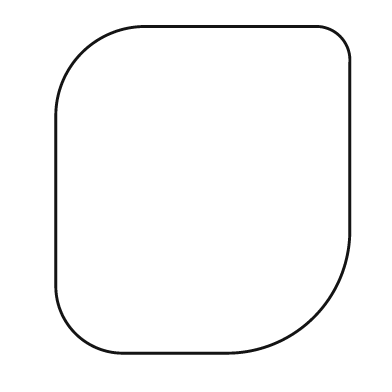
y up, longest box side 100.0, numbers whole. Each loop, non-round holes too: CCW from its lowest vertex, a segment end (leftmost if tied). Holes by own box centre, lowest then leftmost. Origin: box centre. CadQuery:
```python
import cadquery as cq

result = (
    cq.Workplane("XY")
    .moveTo(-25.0, -50.0)
    .lineTo(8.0, -50.0)
    .threePointArc((34.0, -39.0), (45.0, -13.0))
    .lineTo(45.0, 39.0)
    .threePointArc((42.0, 47.0), (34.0, 50.0))
    .lineTo(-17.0, 50.0)
    .threePointArc((-37.0, 42.0), (-45.0, 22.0))
    .lineTo(-45.0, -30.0)
    .threePointArc((-39.0, -44.0), (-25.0, -50.0))
    .close()
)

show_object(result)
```